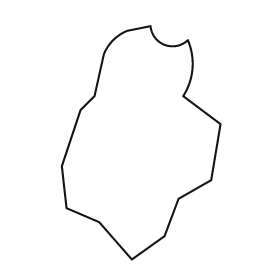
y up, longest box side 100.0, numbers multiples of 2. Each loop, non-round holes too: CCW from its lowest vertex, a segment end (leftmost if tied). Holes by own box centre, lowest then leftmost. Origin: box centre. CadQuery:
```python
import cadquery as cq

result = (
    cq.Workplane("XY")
    .moveTo(-4.0, -50.0)
    .lineTo(10.0, -40.0)
    .lineTo(16.0, -24.0)
    .lineTo(30.0, -16.0)
    .lineTo(34.0, 8.0)
    .lineTo(18.0, 20.0)
    .threePointArc((22.0, 32.0), (20.0, 44.0))
    .threePointArc((10.0, 42.0), (4.0, 50.0))
    .lineTo(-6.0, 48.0)
    .threePointArc((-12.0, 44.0), (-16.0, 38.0))
    .lineTo(-20.0, 20.0)
    .lineTo(-26.0, 14.0)
    .lineTo(-34.0, -10.0)
    .lineTo(-32.0, -28.0)
    .lineTo(-18.0, -34.0)
    .close()
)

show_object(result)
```